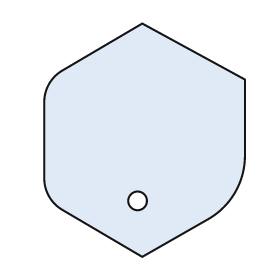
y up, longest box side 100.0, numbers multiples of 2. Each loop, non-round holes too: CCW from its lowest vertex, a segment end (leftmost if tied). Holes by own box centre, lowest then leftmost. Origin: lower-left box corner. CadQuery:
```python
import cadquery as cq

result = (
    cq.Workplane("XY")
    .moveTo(42.0, 0.0)
    .lineTo(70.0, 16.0)
    .threePointArc((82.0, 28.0), (86.0, 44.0))
    .lineTo(86.0, 76.0)
    .lineTo(42.0, 100.0)
    .lineTo(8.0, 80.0)
    .threePointArc((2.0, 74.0), (0.0, 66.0))
    .lineTo(0.0, 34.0)
    .threePointArc((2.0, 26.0), (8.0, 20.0))
    .close()
    .moveTo(40.0, 24.0)
    .circle(4.0)
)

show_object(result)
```